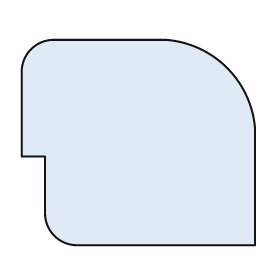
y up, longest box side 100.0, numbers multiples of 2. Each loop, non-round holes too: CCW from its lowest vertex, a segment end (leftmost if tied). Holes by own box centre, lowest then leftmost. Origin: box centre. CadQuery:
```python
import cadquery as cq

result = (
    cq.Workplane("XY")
    .moveTo(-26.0, -44.0)
    .lineTo(50.0, -44.0)
    .lineTo(50.0, 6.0)
    .threePointArc((38.0, 32.0), (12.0, 44.0))
    .lineTo(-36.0, 44.0)
    .threePointArc((-46.0, 40.0), (-50.0, 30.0))
    .lineTo(-50.0, -6.0)
    .lineTo(-40.0, -6.0)
    .lineTo(-40.0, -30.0)
    .threePointArc((-36.0, -40.0), (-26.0, -44.0))
    .close()
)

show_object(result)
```